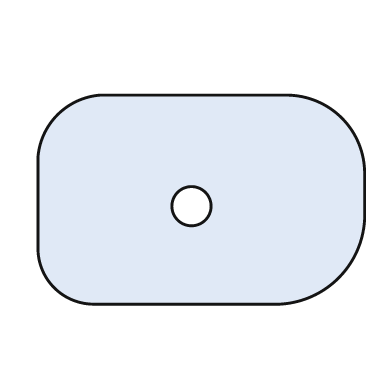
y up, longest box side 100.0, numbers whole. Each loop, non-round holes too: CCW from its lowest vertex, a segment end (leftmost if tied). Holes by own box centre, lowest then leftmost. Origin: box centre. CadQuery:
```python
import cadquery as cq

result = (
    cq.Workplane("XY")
    .moveTo(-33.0, -32.0)
    .lineTo(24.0, -32.0)
    .threePointArc((42.0, -24.0), (50.0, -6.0))
    .lineTo(50.0, 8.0)
    .threePointArc((43.0, 25.0), (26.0, 32.0))
    .lineTo(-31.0, 32.0)
    .threePointArc((-44.0, 26.0), (-50.0, 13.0))
    .lineTo(-50.0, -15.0)
    .threePointArc((-45.0, -27.0), (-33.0, -32.0))
    .close()
    .moveTo(-3.0, -2.0)
    .circle(6.0)
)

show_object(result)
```